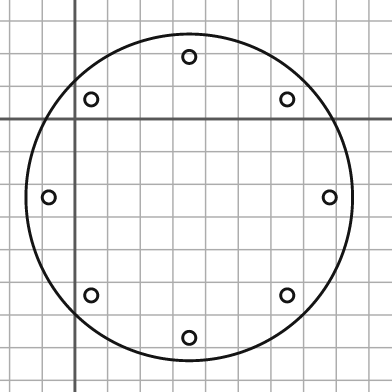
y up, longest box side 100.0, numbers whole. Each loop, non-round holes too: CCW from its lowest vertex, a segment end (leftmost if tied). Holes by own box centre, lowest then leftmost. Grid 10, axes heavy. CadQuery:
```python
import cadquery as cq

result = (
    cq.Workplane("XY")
    .moveTo(35.0, -24.0)
    .circle(50.0)
    .moveTo(35.0, -67.0)
    .circle(2.0)
    .moveTo(5.0, -54.0)
    .circle(2.0)
    .moveTo(65.0, -54.0)
    .circle(2.0)
    .moveTo(-8.0, -24.0)
    .circle(2.0)
    .moveTo(78.0, -24.0)
    .circle(2.0)
    .moveTo(5.0, 6.0)
    .circle(2.0)
    .moveTo(65.0, 6.0)
    .circle(2.0)
    .moveTo(35.0, 19.0)
    .circle(2.0)
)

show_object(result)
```